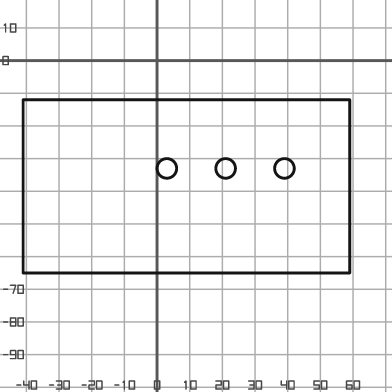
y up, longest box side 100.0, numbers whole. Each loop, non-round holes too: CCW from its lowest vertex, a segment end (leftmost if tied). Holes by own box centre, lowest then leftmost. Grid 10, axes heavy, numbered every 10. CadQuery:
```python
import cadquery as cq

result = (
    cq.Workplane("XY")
    .moveTo(-41.0, -65.0)
    .lineTo(59.0, -65.0)
    .lineTo(59.0, -12.0)
    .lineTo(-41.0, -12.0)
    .close()
    .moveTo(3.0, -33.0)
    .circle(3.0)
    .moveTo(21.0, -33.0)
    .circle(3.0)
    .moveTo(39.0, -33.0)
    .circle(3.0)
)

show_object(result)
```